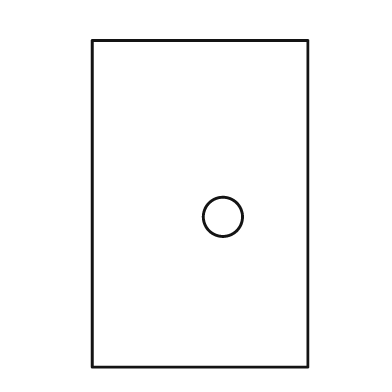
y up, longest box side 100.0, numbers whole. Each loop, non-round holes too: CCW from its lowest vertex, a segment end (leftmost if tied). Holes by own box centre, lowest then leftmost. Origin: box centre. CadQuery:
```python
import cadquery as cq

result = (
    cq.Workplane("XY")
    .moveTo(-33.0, -50.0)
    .lineTo(33.0, -50.0)
    .lineTo(33.0, 50.0)
    .lineTo(-33.0, 50.0)
    .close()
    .moveTo(7.0, -4.0)
    .circle(6.0)
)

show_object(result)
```